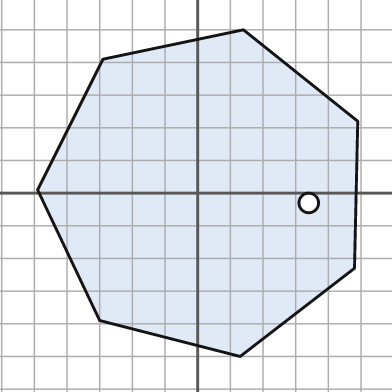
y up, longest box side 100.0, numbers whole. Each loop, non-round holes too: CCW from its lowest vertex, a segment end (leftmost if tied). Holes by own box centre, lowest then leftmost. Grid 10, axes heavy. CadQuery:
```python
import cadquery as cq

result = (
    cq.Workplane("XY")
    .moveTo(13.0, -50.0)
    .lineTo(48.0, -23.0)
    .lineTo(49.0, 22.0)
    .lineTo(14.0, 50.0)
    .lineTo(-29.0, 41.0)
    .lineTo(-49.0, 1.0)
    .lineTo(-30.0, -39.0)
    .close()
    .moveTo(34.0, -3.0)
    .circle(3.0)
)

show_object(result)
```